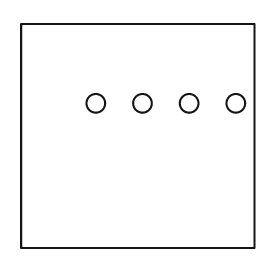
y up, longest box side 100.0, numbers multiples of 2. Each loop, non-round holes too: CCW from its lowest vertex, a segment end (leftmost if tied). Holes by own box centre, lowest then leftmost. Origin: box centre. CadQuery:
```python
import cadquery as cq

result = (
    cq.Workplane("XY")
    .moveTo(-50.0, -48.0)
    .lineTo(50.0, -48.0)
    .lineTo(50.0, 48.0)
    .lineTo(-50.0, 48.0)
    .close()
    .moveTo(-18.0, 14.0)
    .circle(4.0)
    .moveTo(2.0, 14.0)
    .circle(4.0)
    .moveTo(22.0, 14.0)
    .circle(4.0)
    .moveTo(42.0, 14.0)
    .circle(4.0)
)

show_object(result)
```